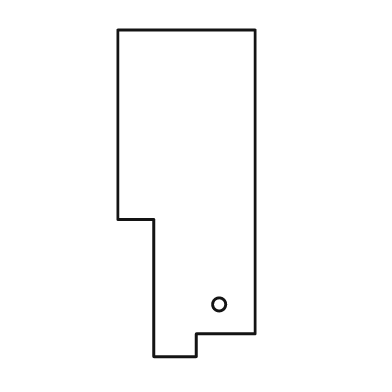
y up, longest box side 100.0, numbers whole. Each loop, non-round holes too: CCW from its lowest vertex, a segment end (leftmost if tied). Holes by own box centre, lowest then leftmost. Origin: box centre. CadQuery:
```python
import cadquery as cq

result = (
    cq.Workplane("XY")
    .moveTo(-10.0, -50.0)
    .lineTo(3.0, -50.0)
    .lineTo(3.0, -43.0)
    .lineTo(21.0, -43.0)
    .lineTo(21.0, 50.0)
    .lineTo(-21.0, 50.0)
    .lineTo(-21.0, -8.0)
    .lineTo(-10.0, -8.0)
    .close()
    .moveTo(10.0, -34.0)
    .circle(2.0)
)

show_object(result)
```